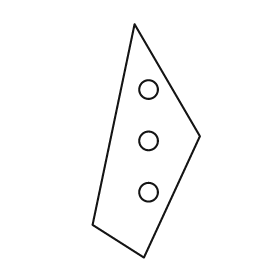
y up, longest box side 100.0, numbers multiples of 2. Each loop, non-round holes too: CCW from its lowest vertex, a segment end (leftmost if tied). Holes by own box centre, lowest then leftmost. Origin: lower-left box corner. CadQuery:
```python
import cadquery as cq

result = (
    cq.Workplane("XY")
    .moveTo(22.0, 0.0)
    .lineTo(46.0, 52.0)
    .lineTo(18.0, 100.0)
    .lineTo(0.0, 14.0)
    .close()
    .moveTo(24.0, 28.0)
    .circle(4.0)
    .moveTo(24.0, 50.0)
    .circle(4.0)
    .moveTo(24.0, 72.0)
    .circle(4.0)
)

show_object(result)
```